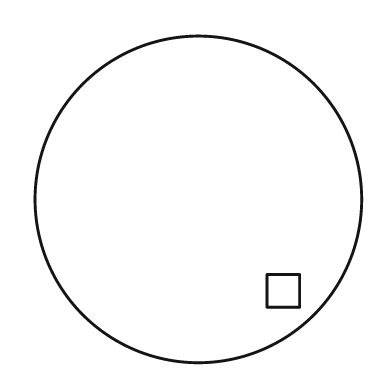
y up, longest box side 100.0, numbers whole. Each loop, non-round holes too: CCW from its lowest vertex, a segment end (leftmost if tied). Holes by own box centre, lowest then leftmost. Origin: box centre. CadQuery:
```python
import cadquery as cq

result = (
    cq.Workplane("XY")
    .moveTo(0.0, 0.0)
    .circle(50.0)
    .moveTo(21.0, -33.0)
    .lineTo(31.0, -33.0)
    .lineTo(31.0, -23.0)
    .lineTo(21.0, -23.0)
    .close()
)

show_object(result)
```